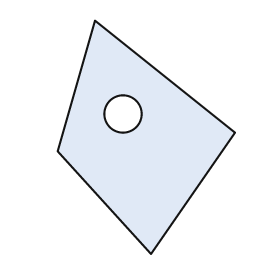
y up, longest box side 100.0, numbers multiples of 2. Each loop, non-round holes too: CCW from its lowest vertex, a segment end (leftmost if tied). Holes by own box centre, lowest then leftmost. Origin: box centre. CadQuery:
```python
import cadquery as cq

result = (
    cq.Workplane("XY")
    .moveTo(2.0, -50.0)
    .lineTo(38.0, 2.0)
    .lineTo(-22.0, 50.0)
    .lineTo(-38.0, -6.0)
    .close()
    .moveTo(-10.0, 10.0)
    .circle(8.0)
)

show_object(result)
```